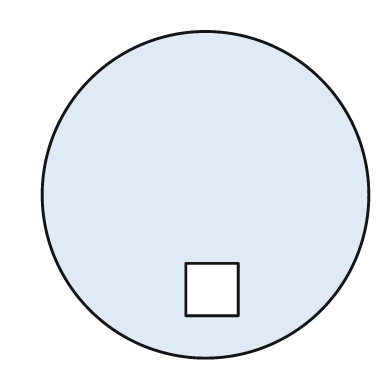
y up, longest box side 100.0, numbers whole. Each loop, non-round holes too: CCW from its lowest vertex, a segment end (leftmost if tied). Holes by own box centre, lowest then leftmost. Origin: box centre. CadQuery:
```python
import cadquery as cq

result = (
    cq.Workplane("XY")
    .moveTo(0.0, 0.0)
    .circle(50.0)
    .moveTo(-6.0, -37.0)
    .lineTo(10.0, -37.0)
    .lineTo(10.0, -21.0)
    .lineTo(-6.0, -21.0)
    .close()
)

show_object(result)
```